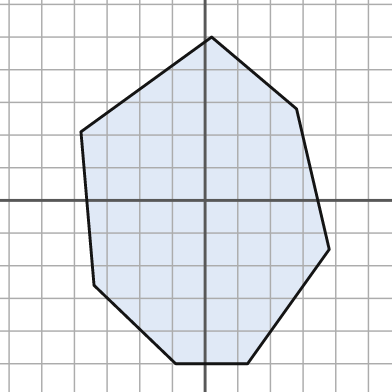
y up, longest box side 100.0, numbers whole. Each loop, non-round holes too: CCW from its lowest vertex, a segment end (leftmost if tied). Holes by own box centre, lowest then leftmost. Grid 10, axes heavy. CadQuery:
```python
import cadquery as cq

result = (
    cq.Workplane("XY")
    .moveTo(-9.0, -50.0)
    .lineTo(13.0, -50.0)
    .lineTo(38.0, -15.0)
    .lineTo(28.0, 28.0)
    .lineTo(2.0, 50.0)
    .lineTo(-38.0, 21.0)
    .lineTo(-34.0, -26.0)
    .close()
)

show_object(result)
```